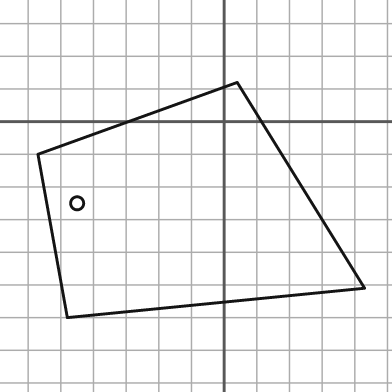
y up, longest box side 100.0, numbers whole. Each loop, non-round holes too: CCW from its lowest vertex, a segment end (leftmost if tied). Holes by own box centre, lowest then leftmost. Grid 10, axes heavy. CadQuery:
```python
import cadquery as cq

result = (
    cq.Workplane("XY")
    .moveTo(-48.0, -60.0)
    .lineTo(43.0, -51.0)
    .lineTo(4.0, 12.0)
    .lineTo(-57.0, -10.0)
    .close()
    .moveTo(-45.0, -25.0)
    .circle(2.0)
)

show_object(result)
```